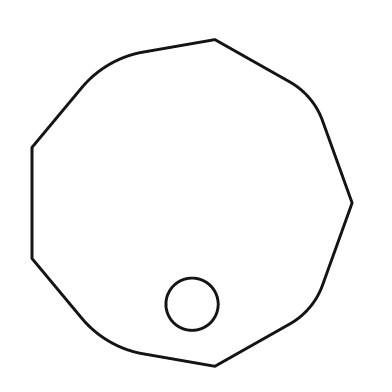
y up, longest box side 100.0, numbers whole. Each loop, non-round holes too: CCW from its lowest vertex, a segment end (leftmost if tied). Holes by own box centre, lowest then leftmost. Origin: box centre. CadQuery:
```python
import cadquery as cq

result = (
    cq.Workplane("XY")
    .moveTo(7.0, -50.0)
    .lineTo(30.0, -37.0)
    .threePointArc((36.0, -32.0), (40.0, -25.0))
    .lineTo(49.0, 0.0)
    .lineTo(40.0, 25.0)
    .threePointArc((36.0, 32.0), (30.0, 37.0))
    .lineTo(7.0, 50.0)
    .lineTo(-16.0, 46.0)
    .threePointArc((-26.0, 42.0), (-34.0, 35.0))
    .lineTo(-49.0, 17.0)
    .lineTo(-49.0, -17.0)
    .lineTo(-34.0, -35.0)
    .threePointArc((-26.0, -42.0), (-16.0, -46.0))
    .close()
    .moveTo(0.0, -31.0)
    .circle(8.0)
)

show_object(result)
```